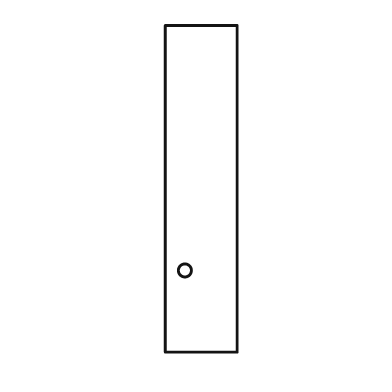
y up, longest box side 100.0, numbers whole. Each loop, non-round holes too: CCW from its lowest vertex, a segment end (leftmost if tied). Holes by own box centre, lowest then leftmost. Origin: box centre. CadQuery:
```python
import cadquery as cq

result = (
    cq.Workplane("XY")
    .moveTo(-11.0, -50.0)
    .lineTo(11.0, -50.0)
    .lineTo(11.0, 50.0)
    .lineTo(-11.0, 50.0)
    .close()
    .moveTo(-5.0, -25.0)
    .circle(2.0)
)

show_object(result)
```